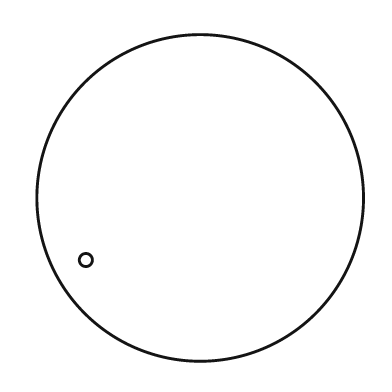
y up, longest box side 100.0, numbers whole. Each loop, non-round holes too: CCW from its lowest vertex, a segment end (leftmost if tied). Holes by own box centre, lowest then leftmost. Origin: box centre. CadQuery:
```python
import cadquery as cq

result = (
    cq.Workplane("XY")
    .moveTo(0.0, 0.0)
    .circle(50.0)
    .moveTo(-35.0, -19.0)
    .circle(2.0)
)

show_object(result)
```